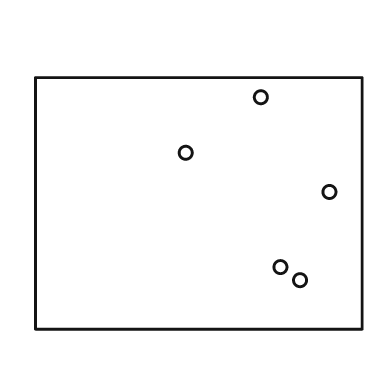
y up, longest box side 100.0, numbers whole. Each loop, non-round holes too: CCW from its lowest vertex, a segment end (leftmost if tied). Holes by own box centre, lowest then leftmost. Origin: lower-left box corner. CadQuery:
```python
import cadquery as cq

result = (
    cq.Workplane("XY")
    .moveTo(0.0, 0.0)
    .lineTo(100.0, 0.0)
    .lineTo(100.0, 77.0)
    .lineTo(0.0, 77.0)
    .close()
    .moveTo(81.0, 15.0)
    .circle(2.0)
    .moveTo(75.0, 19.0)
    .circle(2.0)
    .moveTo(90.0, 42.0)
    .circle(2.0)
    .moveTo(46.0, 54.0)
    .circle(2.0)
    .moveTo(69.0, 71.0)
    .circle(2.0)
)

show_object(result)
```